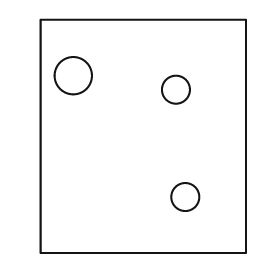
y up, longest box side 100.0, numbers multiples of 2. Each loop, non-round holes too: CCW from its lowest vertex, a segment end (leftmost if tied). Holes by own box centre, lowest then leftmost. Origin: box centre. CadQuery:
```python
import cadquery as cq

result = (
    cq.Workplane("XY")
    .moveTo(-44.0, -50.0)
    .lineTo(44.0, -50.0)
    .lineTo(44.0, 50.0)
    .lineTo(-44.0, 50.0)
    .close()
    .moveTo(18.0, -26.0)
    .circle(6.0)
    .moveTo(14.0, 20.0)
    .circle(6.0)
    .moveTo(-30.0, 26.0)
    .circle(8.0)
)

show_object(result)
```